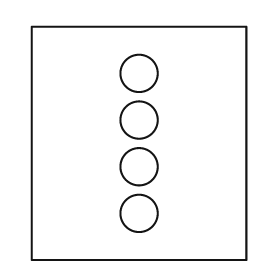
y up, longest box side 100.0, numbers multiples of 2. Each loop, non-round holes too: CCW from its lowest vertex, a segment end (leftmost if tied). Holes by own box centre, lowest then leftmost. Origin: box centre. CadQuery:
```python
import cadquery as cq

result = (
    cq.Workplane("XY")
    .moveTo(-46.0, -50.0)
    .lineTo(46.0, -50.0)
    .lineTo(46.0, 50.0)
    .lineTo(-46.0, 50.0)
    .close()
    .moveTo(0.0, -30.0)
    .circle(8.0)
    .moveTo(0.0, -10.0)
    .circle(8.0)
    .moveTo(0.0, 10.0)
    .circle(8.0)
    .moveTo(0.0, 30.0)
    .circle(8.0)
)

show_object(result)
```